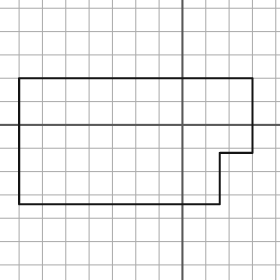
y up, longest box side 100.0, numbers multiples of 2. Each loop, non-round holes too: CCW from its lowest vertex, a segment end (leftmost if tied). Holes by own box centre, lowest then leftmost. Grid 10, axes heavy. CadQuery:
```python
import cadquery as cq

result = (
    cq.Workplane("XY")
    .moveTo(-70.0, -34.0)
    .lineTo(16.0, -34.0)
    .lineTo(16.0, -12.0)
    .lineTo(30.0, -12.0)
    .lineTo(30.0, 20.0)
    .lineTo(-70.0, 20.0)
    .close()
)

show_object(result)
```